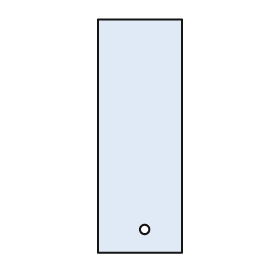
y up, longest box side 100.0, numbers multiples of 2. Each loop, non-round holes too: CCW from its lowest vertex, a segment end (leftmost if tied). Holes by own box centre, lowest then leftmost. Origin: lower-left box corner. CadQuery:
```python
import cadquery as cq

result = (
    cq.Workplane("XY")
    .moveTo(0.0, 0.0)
    .lineTo(36.0, 0.0)
    .lineTo(36.0, 100.0)
    .lineTo(0.0, 100.0)
    .close()
    .moveTo(20.0, 10.0)
    .circle(2.0)
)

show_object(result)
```